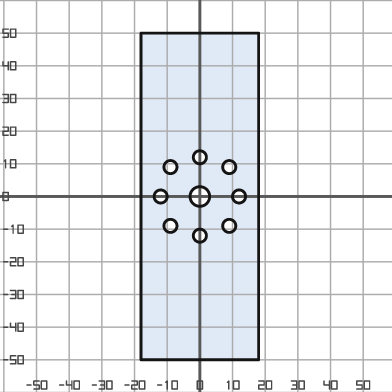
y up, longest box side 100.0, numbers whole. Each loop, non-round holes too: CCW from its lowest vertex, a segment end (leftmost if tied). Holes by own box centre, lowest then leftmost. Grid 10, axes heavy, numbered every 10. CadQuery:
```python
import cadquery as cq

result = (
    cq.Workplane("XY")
    .moveTo(-18.0, -50.0)
    .lineTo(18.0, -50.0)
    .lineTo(18.0, 50.0)
    .lineTo(-18.0, 50.0)
    .close()
    .moveTo(0.0, -12.0)
    .circle(2.0)
    .moveTo(-9.0, -9.0)
    .circle(2.0)
    .moveTo(9.0, -9.0)
    .circle(2.0)
    .moveTo(-12.0, 0.0)
    .circle(2.0)
    .moveTo(0.0, 0.0)
    .circle(3.0)
    .moveTo(12.0, 0.0)
    .circle(2.0)
    .moveTo(-9.0, 9.0)
    .circle(2.0)
    .moveTo(9.0, 9.0)
    .circle(2.0)
    .moveTo(0.0, 12.0)
    .circle(2.0)
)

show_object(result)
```